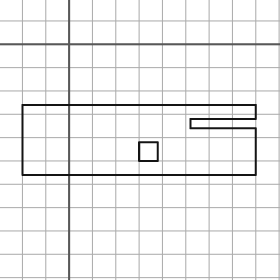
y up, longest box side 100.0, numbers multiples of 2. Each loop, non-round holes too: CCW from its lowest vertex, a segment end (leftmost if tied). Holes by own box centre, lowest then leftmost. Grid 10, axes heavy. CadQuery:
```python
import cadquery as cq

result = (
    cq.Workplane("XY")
    .moveTo(-20.0, -56.0)
    .lineTo(80.0, -56.0)
    .lineTo(80.0, -36.0)
    .lineTo(52.0, -36.0)
    .lineTo(52.0, -32.0)
    .lineTo(80.0, -32.0)
    .lineTo(80.0, -26.0)
    .lineTo(-20.0, -26.0)
    .close()
    .moveTo(30.0, -50.0)
    .lineTo(38.0, -50.0)
    .lineTo(38.0, -42.0)
    .lineTo(30.0, -42.0)
    .close()
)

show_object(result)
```